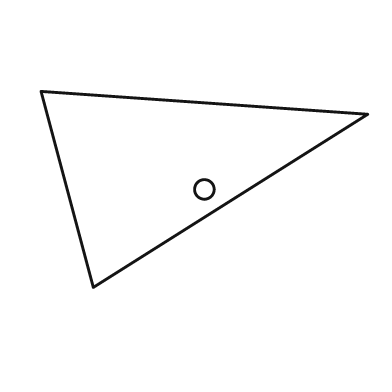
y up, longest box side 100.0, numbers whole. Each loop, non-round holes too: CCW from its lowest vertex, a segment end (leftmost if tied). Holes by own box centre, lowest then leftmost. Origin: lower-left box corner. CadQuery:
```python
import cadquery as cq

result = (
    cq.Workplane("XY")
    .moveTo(16.0, 0.0)
    .lineTo(100.0, 53.0)
    .lineTo(0.0, 60.0)
    .close()
    .moveTo(50.0, 30.0)
    .circle(3.0)
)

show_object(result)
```